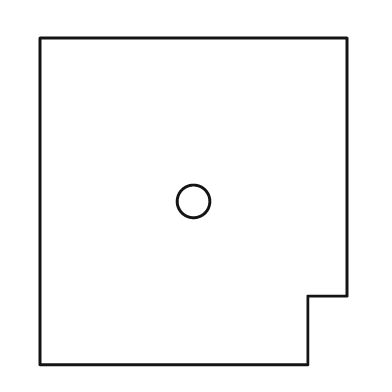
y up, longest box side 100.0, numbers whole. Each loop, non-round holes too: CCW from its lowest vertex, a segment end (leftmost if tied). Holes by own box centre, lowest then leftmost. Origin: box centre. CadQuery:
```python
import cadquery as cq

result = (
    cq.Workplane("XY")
    .moveTo(-47.0, -50.0)
    .lineTo(35.0, -50.0)
    .lineTo(35.0, -29.0)
    .lineTo(47.0, -29.0)
    .lineTo(47.0, 50.0)
    .lineTo(-47.0, 50.0)
    .close()
    .moveTo(0.0, 0.0)
    .circle(5.0)
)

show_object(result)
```